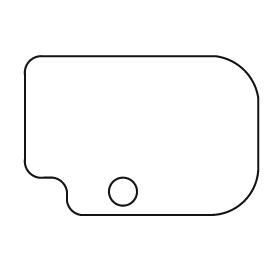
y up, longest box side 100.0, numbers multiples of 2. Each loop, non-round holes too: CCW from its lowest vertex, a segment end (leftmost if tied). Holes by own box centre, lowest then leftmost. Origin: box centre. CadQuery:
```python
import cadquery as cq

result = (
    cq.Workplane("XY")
    .moveTo(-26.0, -34.0)
    .lineTo(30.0, -34.0)
    .threePointArc((44.0, -28.0), (50.0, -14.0))
    .lineTo(50.0, 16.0)
    .threePointArc((44.0, 28.0), (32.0, 34.0))
    .lineTo(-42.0, 34.0)
    .threePointArc((-48.0, 32.0), (-50.0, 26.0))
    .lineTo(-50.0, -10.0)
    .threePointArc((-48.0, -16.0), (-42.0, -18.0))
    .lineTo(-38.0, -18.0)
    .threePointArc((-34.0, -20.0), (-32.0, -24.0))
    .lineTo(-32.0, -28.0)
    .threePointArc((-30.0, -32.0), (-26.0, -34.0))
    .close()
    .moveTo(-8.0, -24.0)
    .circle(6.0)
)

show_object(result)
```